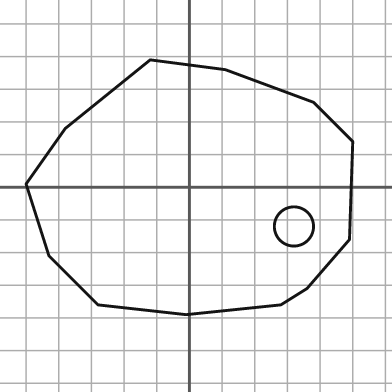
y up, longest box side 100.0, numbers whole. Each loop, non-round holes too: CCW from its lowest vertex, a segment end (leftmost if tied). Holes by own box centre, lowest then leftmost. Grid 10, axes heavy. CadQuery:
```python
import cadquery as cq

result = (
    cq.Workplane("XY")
    .moveTo(-1.0, -39.0)
    .lineTo(28.0, -36.0)
    .lineTo(36.0, -31.0)
    .lineTo(49.0, -16.0)
    .lineTo(50.0, 14.0)
    .lineTo(38.0, 26.0)
    .lineTo(11.0, 36.0)
    .lineTo(-12.0, 39.0)
    .lineTo(-38.0, 18.0)
    .lineTo(-50.0, 1.0)
    .lineTo(-43.0, -21.0)
    .lineTo(-28.0, -36.0)
    .close()
    .moveTo(32.0, -12.0)
    .circle(6.0)
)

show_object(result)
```